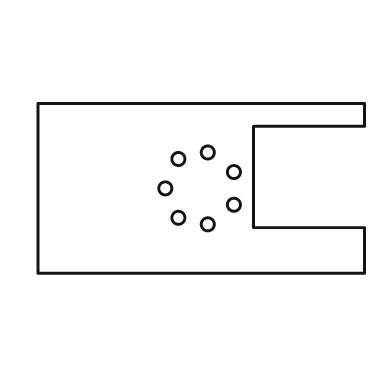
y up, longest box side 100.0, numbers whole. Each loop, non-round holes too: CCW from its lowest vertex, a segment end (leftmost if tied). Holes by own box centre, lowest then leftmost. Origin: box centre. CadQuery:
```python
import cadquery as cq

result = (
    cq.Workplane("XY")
    .moveTo(-50.0, -26.0)
    .lineTo(50.0, -26.0)
    .lineTo(50.0, -12.0)
    .lineTo(16.0, -12.0)
    .lineTo(16.0, 19.0)
    .lineTo(50.0, 19.0)
    .lineTo(50.0, 26.0)
    .lineTo(-50.0, 26.0)
    .close()
    .moveTo(2.0, -11.0)
    .circle(2.0)
    .moveTo(-7.0, -9.0)
    .circle(2.0)
    .moveTo(10.0, -5.0)
    .circle(2.0)
    .moveTo(-11.0, 0.0)
    .circle(2.0)
    .moveTo(10.0, 5.0)
    .circle(2.0)
    .moveTo(-7.0, 9.0)
    .circle(2.0)
    .moveTo(2.0, 11.0)
    .circle(2.0)
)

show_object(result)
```